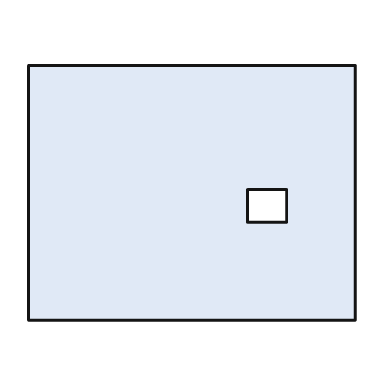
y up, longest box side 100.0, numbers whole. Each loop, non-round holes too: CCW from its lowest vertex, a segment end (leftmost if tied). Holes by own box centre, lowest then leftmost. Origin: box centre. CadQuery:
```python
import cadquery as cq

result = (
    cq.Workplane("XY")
    .moveTo(-50.0, -39.0)
    .lineTo(50.0, -39.0)
    .lineTo(50.0, 39.0)
    .lineTo(-50.0, 39.0)
    .close()
    .moveTo(17.0, -9.0)
    .lineTo(29.0, -9.0)
    .lineTo(29.0, 1.0)
    .lineTo(17.0, 1.0)
    .close()
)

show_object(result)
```